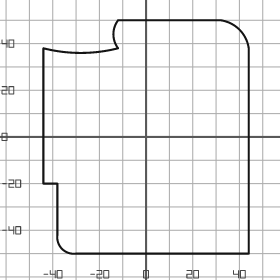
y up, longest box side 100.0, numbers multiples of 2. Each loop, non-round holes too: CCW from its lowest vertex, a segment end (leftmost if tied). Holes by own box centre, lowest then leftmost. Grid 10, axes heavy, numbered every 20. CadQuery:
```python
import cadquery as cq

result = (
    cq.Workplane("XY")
    .moveTo(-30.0, -50.0)
    .lineTo(44.0, -50.0)
    .lineTo(44.0, 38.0)
    .threePointArc((40.0, 46.0), (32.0, 50.0))
    .lineTo(-12.0, 50.0)
    .threePointArc((-14.0, 44.0), (-12.0, 38.0))
    .threePointArc((-28.0, 36.0), (-44.0, 38.0))
    .lineTo(-44.0, -20.0)
    .lineTo(-38.0, -20.0)
    .lineTo(-38.0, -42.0)
    .threePointArc((-36.0, -48.0), (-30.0, -50.0))
    .close()
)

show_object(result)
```